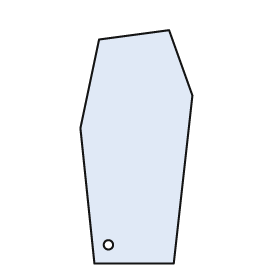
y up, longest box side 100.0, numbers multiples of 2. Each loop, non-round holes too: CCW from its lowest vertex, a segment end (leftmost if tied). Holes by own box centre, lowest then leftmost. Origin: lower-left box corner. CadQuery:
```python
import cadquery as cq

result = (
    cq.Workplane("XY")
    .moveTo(6.0, 0.0)
    .lineTo(40.0, 0.0)
    .lineTo(48.0, 72.0)
    .lineTo(38.0, 100.0)
    .lineTo(8.0, 96.0)
    .lineTo(0.0, 58.0)
    .close()
    .moveTo(12.0, 8.0)
    .circle(2.0)
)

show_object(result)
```